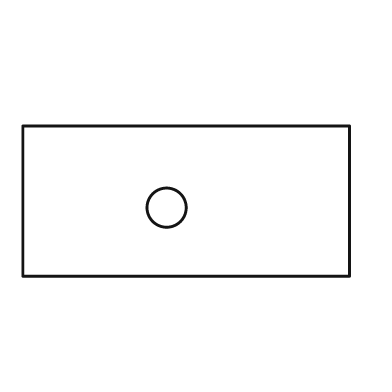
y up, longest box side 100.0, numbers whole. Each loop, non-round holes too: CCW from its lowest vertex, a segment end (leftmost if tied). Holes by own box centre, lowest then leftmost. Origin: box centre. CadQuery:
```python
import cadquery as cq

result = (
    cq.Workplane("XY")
    .moveTo(-50.0, -23.0)
    .lineTo(50.0, -23.0)
    .lineTo(50.0, 23.0)
    .lineTo(-50.0, 23.0)
    .close()
    .moveTo(-6.0, -2.0)
    .circle(6.0)
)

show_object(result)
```